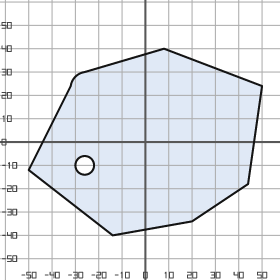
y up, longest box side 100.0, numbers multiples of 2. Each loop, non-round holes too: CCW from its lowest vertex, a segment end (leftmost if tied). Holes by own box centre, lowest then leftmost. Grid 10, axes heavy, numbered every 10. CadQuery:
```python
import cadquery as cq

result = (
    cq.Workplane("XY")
    .moveTo(-14.0, -40.0)
    .lineTo(20.0, -34.0)
    .lineTo(44.0, -18.0)
    .lineTo(50.0, 24.0)
    .lineTo(8.0, 40.0)
    .lineTo(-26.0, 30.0)
    .threePointArc((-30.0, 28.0), (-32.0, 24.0))
    .lineTo(-50.0, -12.0)
    .close()
    .moveTo(-26.0, -10.0)
    .circle(4.0)
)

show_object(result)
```